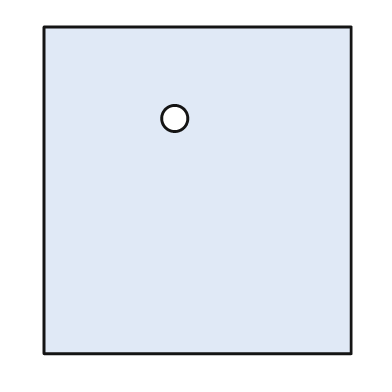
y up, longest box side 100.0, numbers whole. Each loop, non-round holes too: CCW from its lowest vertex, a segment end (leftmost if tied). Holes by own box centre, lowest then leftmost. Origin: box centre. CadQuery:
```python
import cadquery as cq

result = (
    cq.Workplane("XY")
    .moveTo(-47.0, -50.0)
    .lineTo(47.0, -50.0)
    .lineTo(47.0, 50.0)
    .lineTo(-47.0, 50.0)
    .close()
    .moveTo(-7.0, 22.0)
    .circle(4.0)
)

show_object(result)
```